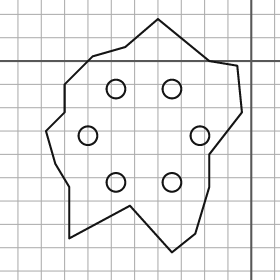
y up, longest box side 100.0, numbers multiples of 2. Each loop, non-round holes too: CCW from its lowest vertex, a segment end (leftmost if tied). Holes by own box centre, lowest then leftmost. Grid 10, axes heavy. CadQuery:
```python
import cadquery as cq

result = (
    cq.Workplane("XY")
    .moveTo(-34.0, -82.0)
    .lineTo(-24.0, -74.0)
    .lineTo(-18.0, -54.0)
    .lineTo(-18.0, -40.0)
    .lineTo(-4.0, -22.0)
    .lineTo(-6.0, -2.0)
    .lineTo(-18.0, 0.0)
    .lineTo(-40.0, 18.0)
    .lineTo(-54.0, 6.0)
    .lineTo(-68.0, 2.0)
    .lineTo(-80.0, -10.0)
    .lineTo(-80.0, -22.0)
    .lineTo(-88.0, -30.0)
    .lineTo(-84.0, -44.0)
    .lineTo(-78.0, -54.0)
    .lineTo(-78.0, -76.0)
    .lineTo(-52.0, -62.0)
    .close()
    .moveTo(-58.0, -52.0)
    .circle(4.0)
    .moveTo(-34.0, -52.0)
    .circle(4.0)
    .moveTo(-70.0, -32.0)
    .circle(4.0)
    .moveTo(-22.0, -32.0)
    .circle(4.0)
    .moveTo(-58.0, -12.0)
    .circle(4.0)
    .moveTo(-34.0, -12.0)
    .circle(4.0)
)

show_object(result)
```